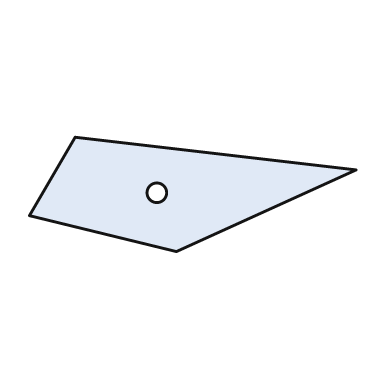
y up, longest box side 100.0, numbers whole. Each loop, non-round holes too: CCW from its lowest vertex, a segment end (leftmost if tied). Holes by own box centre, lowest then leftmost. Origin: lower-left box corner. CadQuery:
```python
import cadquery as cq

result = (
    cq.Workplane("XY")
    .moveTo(45.0, 0.0)
    .lineTo(100.0, 25.0)
    .lineTo(14.0, 35.0)
    .lineTo(0.0, 11.0)
    .close()
    .moveTo(39.0, 18.0)
    .circle(3.0)
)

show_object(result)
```